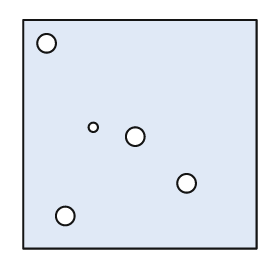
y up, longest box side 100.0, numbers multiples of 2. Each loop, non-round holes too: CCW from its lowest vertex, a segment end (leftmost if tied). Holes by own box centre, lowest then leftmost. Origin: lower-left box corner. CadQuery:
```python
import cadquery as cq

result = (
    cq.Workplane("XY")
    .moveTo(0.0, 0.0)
    .lineTo(100.0, 0.0)
    .lineTo(100.0, 98.0)
    .lineTo(0.0, 98.0)
    .close()
    .moveTo(18.0, 14.0)
    .circle(4.0)
    .moveTo(70.0, 28.0)
    .circle(4.0)
    .moveTo(48.0, 48.0)
    .circle(4.0)
    .moveTo(30.0, 52.0)
    .circle(2.0)
    .moveTo(10.0, 88.0)
    .circle(4.0)
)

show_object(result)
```